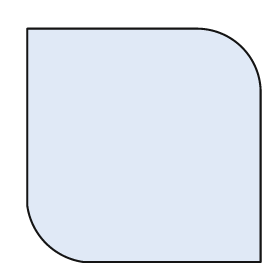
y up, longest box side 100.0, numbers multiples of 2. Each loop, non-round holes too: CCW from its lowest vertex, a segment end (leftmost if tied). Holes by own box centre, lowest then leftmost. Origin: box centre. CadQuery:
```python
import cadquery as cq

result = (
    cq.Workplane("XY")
    .moveTo(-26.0, -50.0)
    .lineTo(50.0, -50.0)
    .lineTo(50.0, 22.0)
    .threePointArc((42.0, 42.0), (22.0, 50.0))
    .lineTo(-50.0, 50.0)
    .lineTo(-50.0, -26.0)
    .threePointArc((-42.0, -42.0), (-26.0, -50.0))
    .close()
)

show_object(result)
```